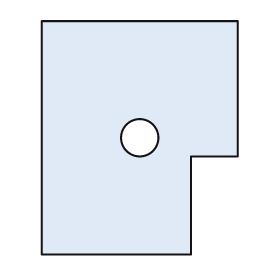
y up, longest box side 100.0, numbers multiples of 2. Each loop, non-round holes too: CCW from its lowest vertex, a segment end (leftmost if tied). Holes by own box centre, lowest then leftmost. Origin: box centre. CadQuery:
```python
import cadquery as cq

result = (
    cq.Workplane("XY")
    .moveTo(-42.0, -50.0)
    .lineTo(22.0, -50.0)
    .lineTo(22.0, -8.0)
    .lineTo(42.0, -8.0)
    .lineTo(42.0, 50.0)
    .lineTo(-42.0, 50.0)
    .close()
    .moveTo(0.0, 0.0)
    .circle(8.0)
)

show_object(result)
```